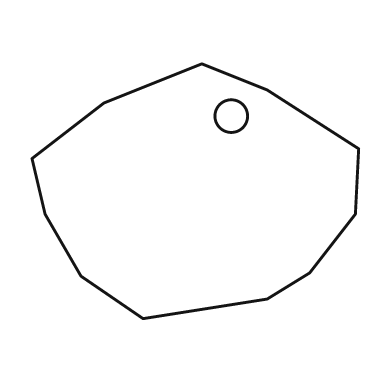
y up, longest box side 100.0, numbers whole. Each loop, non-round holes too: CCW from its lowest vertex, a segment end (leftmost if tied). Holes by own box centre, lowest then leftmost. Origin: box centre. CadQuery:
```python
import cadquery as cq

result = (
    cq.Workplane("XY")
    .moveTo(-16.0, -39.0)
    .lineTo(22.0, -33.0)
    .lineTo(35.0, -25.0)
    .lineTo(49.0, -7.0)
    .lineTo(50.0, 13.0)
    .lineTo(22.0, 31.0)
    .lineTo(2.0, 39.0)
    .lineTo(-28.0, 27.0)
    .lineTo(-50.0, 10.0)
    .lineTo(-46.0, -7.0)
    .lineTo(-35.0, -26.0)
    .close()
    .moveTo(11.0, 23.0)
    .circle(5.0)
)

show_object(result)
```